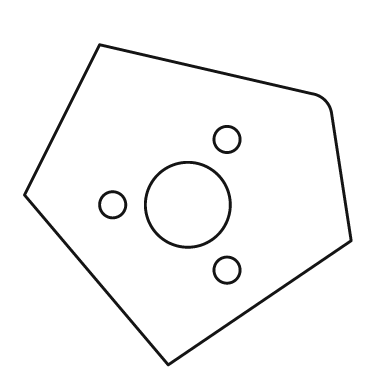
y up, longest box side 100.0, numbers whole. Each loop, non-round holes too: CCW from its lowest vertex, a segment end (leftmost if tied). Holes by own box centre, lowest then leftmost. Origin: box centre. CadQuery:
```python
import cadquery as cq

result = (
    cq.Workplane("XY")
    .moveTo(-6.0, -49.0)
    .lineTo(50.0, -11.0)
    .lineTo(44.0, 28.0)
    .threePointArc((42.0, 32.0), (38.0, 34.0))
    .lineTo(-27.0, 49.0)
    .lineTo(-50.0, 3.0)
    .close()
    .moveTo(12.0, -20.0)
    .circle(4.0)
    .moveTo(-23.0, 0.0)
    .circle(4.0)
    .moveTo(0.0, 0.0)
    .circle(13.0)
    .moveTo(12.0, 20.0)
    .circle(4.0)
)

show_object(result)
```